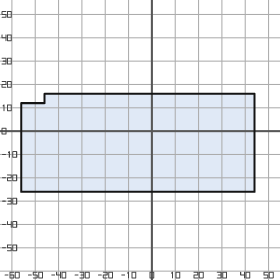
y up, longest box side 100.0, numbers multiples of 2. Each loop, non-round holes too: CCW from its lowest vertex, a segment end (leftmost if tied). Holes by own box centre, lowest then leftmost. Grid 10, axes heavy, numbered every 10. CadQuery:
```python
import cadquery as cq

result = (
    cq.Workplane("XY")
    .moveTo(-56.0, -26.0)
    .lineTo(44.0, -26.0)
    .lineTo(44.0, 16.0)
    .lineTo(-46.0, 16.0)
    .lineTo(-46.0, 12.0)
    .lineTo(-56.0, 12.0)
    .close()
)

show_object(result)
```